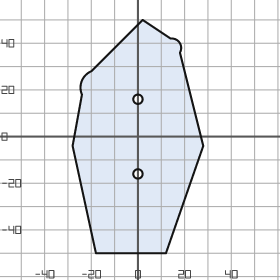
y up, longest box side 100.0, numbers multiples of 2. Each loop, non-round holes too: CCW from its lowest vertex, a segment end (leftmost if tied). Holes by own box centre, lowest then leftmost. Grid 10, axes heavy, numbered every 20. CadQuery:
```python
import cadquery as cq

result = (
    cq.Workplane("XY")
    .moveTo(-18.0, -50.0)
    .lineTo(12.0, -50.0)
    .lineTo(28.0, -4.0)
    .lineTo(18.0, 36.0)
    .threePointArc((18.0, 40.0), (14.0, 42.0))
    .lineTo(2.0, 50.0)
    .lineTo(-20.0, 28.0)
    .threePointArc((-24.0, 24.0), (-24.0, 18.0))
    .lineTo(-28.0, -4.0)
    .close()
    .moveTo(0.0, -16.0)
    .circle(2.0)
    .moveTo(0.0, 16.0)
    .circle(2.0)
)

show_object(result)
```